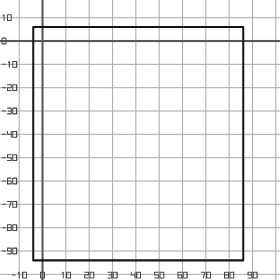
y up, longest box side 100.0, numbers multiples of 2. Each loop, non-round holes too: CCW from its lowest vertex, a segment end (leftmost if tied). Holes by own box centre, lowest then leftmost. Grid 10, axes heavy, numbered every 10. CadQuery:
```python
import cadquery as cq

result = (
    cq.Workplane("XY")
    .moveTo(-4.0, -94.0)
    .lineTo(86.0, -94.0)
    .lineTo(86.0, 6.0)
    .lineTo(-4.0, 6.0)
    .close()
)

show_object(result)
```